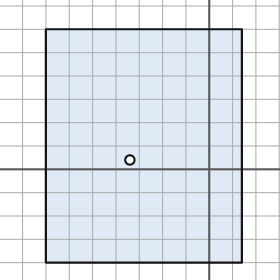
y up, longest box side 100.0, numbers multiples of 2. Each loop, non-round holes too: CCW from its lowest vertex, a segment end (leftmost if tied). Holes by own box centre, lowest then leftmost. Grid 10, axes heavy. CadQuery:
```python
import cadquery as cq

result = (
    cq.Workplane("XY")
    .moveTo(-70.0, -40.0)
    .lineTo(14.0, -40.0)
    .lineTo(14.0, 60.0)
    .lineTo(-70.0, 60.0)
    .close()
    .moveTo(-34.0, 4.0)
    .circle(2.0)
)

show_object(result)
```